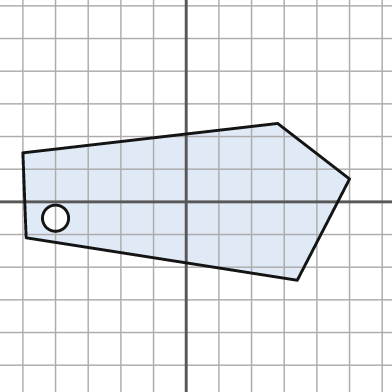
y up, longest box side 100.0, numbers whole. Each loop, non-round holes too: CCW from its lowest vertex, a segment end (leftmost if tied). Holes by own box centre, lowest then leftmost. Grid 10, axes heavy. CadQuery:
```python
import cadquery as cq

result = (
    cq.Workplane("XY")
    .moveTo(34.0, -24.0)
    .lineTo(50.0, 7.0)
    .lineTo(28.0, 24.0)
    .lineTo(-50.0, 15.0)
    .lineTo(-49.0, -11.0)
    .close()
    .moveTo(-40.0, -5.0)
    .circle(4.0)
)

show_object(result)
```